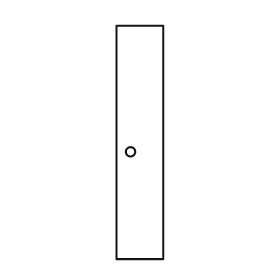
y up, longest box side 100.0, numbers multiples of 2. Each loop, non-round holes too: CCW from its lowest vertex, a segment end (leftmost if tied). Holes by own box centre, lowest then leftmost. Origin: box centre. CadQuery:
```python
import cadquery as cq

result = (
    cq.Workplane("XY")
    .moveTo(-10.0, -50.0)
    .lineTo(10.0, -50.0)
    .lineTo(10.0, 50.0)
    .lineTo(-10.0, 50.0)
    .close()
    .moveTo(-4.0, -4.0)
    .circle(2.0)
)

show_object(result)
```